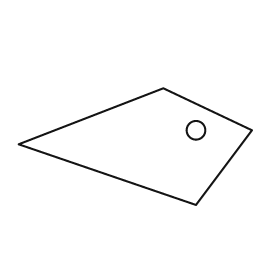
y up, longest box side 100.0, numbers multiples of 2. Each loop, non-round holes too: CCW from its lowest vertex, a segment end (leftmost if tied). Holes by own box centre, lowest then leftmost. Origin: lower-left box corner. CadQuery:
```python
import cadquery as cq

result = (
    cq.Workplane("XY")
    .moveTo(76.0, 0.0)
    .lineTo(100.0, 32.0)
    .lineTo(62.0, 50.0)
    .lineTo(0.0, 26.0)
    .close()
    .moveTo(76.0, 32.0)
    .circle(4.0)
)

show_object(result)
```